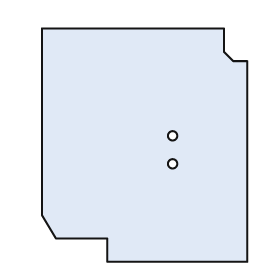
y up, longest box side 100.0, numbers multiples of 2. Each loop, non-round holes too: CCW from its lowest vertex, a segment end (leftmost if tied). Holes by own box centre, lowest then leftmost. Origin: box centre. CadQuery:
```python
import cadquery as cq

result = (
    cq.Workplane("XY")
    .moveTo(-16.0, -50.0)
    .lineTo(44.0, -50.0)
    .lineTo(44.0, 36.0)
    .lineTo(38.0, 36.0)
    .lineTo(34.0, 40.0)
    .lineTo(34.0, 50.0)
    .lineTo(-44.0, 50.0)
    .lineTo(-44.0, -30.0)
    .lineTo(-38.0, -40.0)
    .lineTo(-16.0, -40.0)
    .close()
    .moveTo(12.0, -8.0)
    .circle(2.0)
    .moveTo(12.0, 4.0)
    .circle(2.0)
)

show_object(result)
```